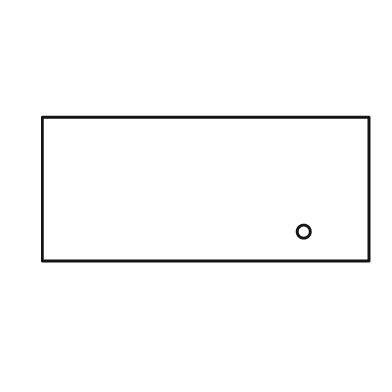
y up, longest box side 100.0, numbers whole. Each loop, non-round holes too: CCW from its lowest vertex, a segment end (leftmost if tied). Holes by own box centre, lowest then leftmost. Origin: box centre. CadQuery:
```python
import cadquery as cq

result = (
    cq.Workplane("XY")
    .moveTo(-50.0, -22.0)
    .lineTo(50.0, -22.0)
    .lineTo(50.0, 22.0)
    .lineTo(-50.0, 22.0)
    .close()
    .moveTo(30.0, -13.0)
    .circle(2.0)
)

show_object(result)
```